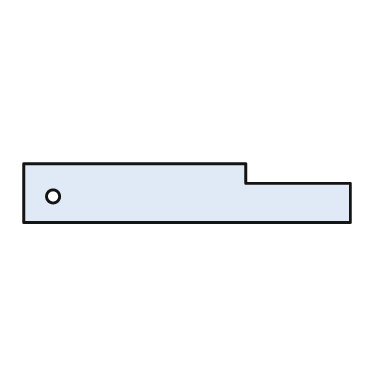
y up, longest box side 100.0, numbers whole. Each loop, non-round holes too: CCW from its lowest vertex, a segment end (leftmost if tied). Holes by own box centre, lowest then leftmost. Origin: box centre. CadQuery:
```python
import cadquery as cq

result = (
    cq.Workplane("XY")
    .moveTo(-50.0, -9.0)
    .lineTo(50.0, -9.0)
    .lineTo(50.0, 3.0)
    .lineTo(18.0, 3.0)
    .lineTo(18.0, 9.0)
    .lineTo(-50.0, 9.0)
    .close()
    .moveTo(-41.0, -1.0)
    .circle(2.0)
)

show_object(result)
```